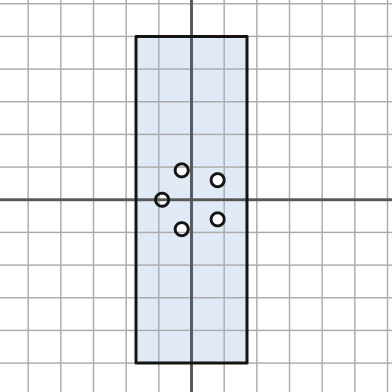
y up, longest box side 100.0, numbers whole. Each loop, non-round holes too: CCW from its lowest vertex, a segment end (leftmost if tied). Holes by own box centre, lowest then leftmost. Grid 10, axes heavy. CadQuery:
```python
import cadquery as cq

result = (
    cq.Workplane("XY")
    .moveTo(-17.0, -50.0)
    .lineTo(17.0, -50.0)
    .lineTo(17.0, 50.0)
    .lineTo(-17.0, 50.0)
    .close()
    .moveTo(-3.0, -9.0)
    .circle(2.0)
    .moveTo(8.0, -6.0)
    .circle(2.0)
    .moveTo(-9.0, 0.0)
    .circle(2.0)
    .moveTo(8.0, 6.0)
    .circle(2.0)
    .moveTo(-3.0, 9.0)
    .circle(2.0)
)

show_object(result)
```